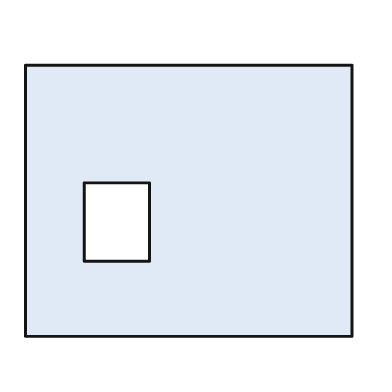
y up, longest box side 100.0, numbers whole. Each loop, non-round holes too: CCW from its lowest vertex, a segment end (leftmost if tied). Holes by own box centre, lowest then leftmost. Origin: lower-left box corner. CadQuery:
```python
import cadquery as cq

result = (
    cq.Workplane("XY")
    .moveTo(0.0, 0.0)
    .lineTo(100.0, 0.0)
    .lineTo(100.0, 83.0)
    .lineTo(0.0, 83.0)
    .close()
    .moveTo(18.0, 23.0)
    .lineTo(38.0, 23.0)
    .lineTo(38.0, 47.0)
    .lineTo(18.0, 47.0)
    .close()
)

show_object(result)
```